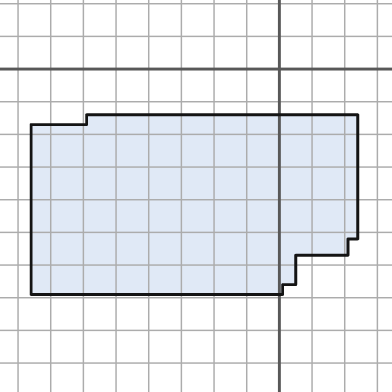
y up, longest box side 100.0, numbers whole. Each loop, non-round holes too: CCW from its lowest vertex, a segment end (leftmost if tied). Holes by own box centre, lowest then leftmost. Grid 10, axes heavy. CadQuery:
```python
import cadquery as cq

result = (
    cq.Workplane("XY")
    .moveTo(-76.0, -69.0)
    .lineTo(1.0, -69.0)
    .lineTo(1.0, -66.0)
    .lineTo(5.0, -66.0)
    .lineTo(5.0, -57.0)
    .lineTo(21.0, -57.0)
    .lineTo(21.0, -52.0)
    .lineTo(24.0, -52.0)
    .lineTo(24.0, -14.0)
    .lineTo(-59.0, -14.0)
    .lineTo(-59.0, -17.0)
    .lineTo(-76.0, -17.0)
    .close()
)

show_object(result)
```